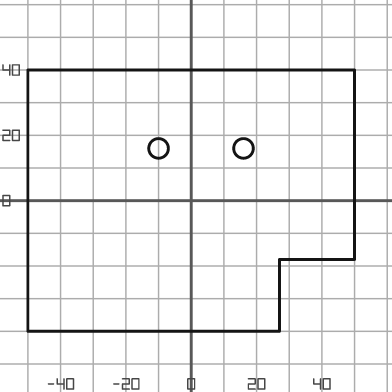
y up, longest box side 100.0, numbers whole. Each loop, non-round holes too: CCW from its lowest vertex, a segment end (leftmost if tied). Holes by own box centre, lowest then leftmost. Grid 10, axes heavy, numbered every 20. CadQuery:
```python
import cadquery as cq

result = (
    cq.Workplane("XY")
    .moveTo(-50.0, -40.0)
    .lineTo(27.0, -40.0)
    .lineTo(27.0, -18.0)
    .lineTo(50.0, -18.0)
    .lineTo(50.0, 40.0)
    .lineTo(-50.0, 40.0)
    .close()
    .moveTo(-10.0, 16.0)
    .circle(3.0)
    .moveTo(16.0, 16.0)
    .circle(3.0)
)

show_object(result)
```